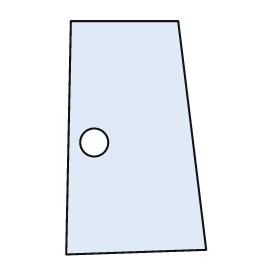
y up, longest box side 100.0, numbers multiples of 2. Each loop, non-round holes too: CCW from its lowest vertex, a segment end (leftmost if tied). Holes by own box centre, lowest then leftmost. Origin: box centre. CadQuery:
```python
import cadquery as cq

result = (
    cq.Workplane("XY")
    .moveTo(-30.0, -50.0)
    .lineTo(30.0, -48.0)
    .lineTo(18.0, 50.0)
    .lineTo(-28.0, 50.0)
    .close()
    .moveTo(-18.0, -2.0)
    .circle(6.0)
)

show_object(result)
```